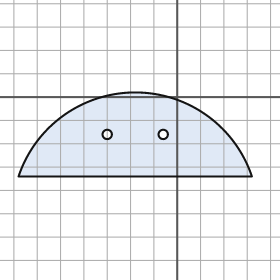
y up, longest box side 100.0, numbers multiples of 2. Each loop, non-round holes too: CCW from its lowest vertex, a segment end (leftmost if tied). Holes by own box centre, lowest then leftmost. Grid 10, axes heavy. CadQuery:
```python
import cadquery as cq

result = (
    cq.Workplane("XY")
    .moveTo(-68.0, -34.0)
    .lineTo(32.0, -34.0)
    .threePointArc((-18.0, 2.0), (-68.0, -34.0))
    .close()
    .moveTo(-30.0, -16.0)
    .circle(2.0)
    .moveTo(-6.0, -16.0)
    .circle(2.0)
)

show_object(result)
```